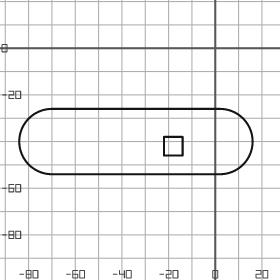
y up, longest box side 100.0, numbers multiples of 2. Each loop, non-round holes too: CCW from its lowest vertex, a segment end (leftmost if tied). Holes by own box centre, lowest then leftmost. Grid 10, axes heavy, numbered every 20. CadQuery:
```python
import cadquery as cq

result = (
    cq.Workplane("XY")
    .moveTo(-70.0, -54.0)
    .lineTo(2.0, -54.0)
    .threePointArc((16.0, -40.0), (2.0, -26.0))
    .lineTo(-70.0, -26.0)
    .threePointArc((-84.0, -40.0), (-70.0, -54.0))
    .close()
    .moveTo(-22.0, -46.0)
    .lineTo(-14.0, -46.0)
    .lineTo(-14.0, -38.0)
    .lineTo(-22.0, -38.0)
    .close()
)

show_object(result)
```